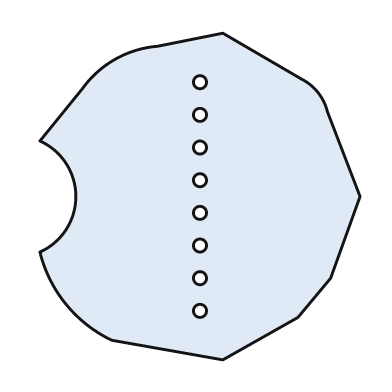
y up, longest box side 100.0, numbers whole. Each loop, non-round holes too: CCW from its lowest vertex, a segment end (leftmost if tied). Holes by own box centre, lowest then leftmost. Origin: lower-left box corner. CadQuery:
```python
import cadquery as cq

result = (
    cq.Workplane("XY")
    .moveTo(56.0, 0.0)
    .lineTo(79.0, 13.0)
    .lineTo(89.0, 25.0)
    .lineTo(98.0, 50.0)
    .lineTo(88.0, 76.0)
    .threePointArc((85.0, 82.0), (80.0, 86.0))
    .lineTo(56.0, 100.0)
    .lineTo(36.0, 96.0)
    .threePointArc((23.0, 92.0), (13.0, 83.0))
    .lineTo(0.0, 67.0)
    .threePointArc((11.0, 50.0), (0.0, 33.0))
    .threePointArc((8.0, 17.0), (22.0, 6.0))
    .close()
    .moveTo(49.0, 15.0)
    .circle(2.0)
    .moveTo(49.0, 25.0)
    .circle(2.0)
    .moveTo(49.0, 35.0)
    .circle(2.0)
    .moveTo(49.0, 45.0)
    .circle(2.0)
    .moveTo(49.0, 55.0)
    .circle(2.0)
    .moveTo(49.0, 65.0)
    .circle(2.0)
    .moveTo(49.0, 75.0)
    .circle(2.0)
    .moveTo(49.0, 85.0)
    .circle(2.0)
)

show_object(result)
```